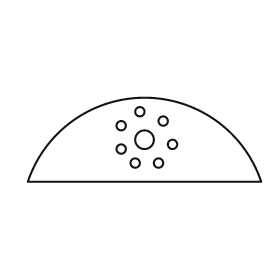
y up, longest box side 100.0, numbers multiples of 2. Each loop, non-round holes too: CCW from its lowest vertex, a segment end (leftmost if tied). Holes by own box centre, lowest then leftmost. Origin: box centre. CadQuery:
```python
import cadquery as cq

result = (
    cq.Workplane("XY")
    .moveTo(-50.0, -18.0)
    .lineTo(50.0, -18.0)
    .threePointArc((0.0, 18.0), (-50.0, -18.0))
    .close()
    .moveTo(-4.0, -10.0)
    .circle(2.0)
    .moveTo(6.0, -10.0)
    .circle(2.0)
    .moveTo(-10.0, -4.0)
    .circle(2.0)
    .moveTo(12.0, -2.0)
    .circle(2.0)
    .moveTo(0.0, 0.0)
    .circle(4.0)
    .moveTo(-10.0, 6.0)
    .circle(2.0)
    .moveTo(8.0, 8.0)
    .circle(2.0)
    .moveTo(-2.0, 12.0)
    .circle(2.0)
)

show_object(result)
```